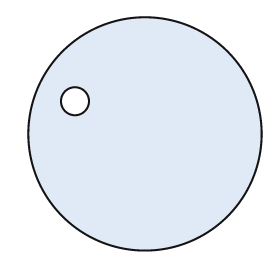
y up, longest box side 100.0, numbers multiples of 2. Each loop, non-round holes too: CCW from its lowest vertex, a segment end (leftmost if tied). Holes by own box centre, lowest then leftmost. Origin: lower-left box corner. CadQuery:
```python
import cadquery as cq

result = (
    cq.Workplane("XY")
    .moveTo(50.0, 50.0)
    .circle(50.0)
    .moveTo(20.0, 64.0)
    .circle(6.0)
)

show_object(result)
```